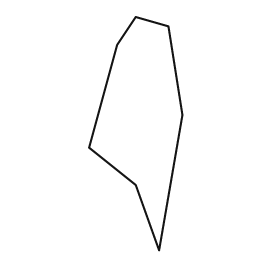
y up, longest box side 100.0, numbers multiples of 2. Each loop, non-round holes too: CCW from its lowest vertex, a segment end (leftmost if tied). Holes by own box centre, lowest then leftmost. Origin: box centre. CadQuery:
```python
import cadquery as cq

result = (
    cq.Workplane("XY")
    .moveTo(10.0, -50.0)
    .lineTo(20.0, 8.0)
    .lineTo(14.0, 46.0)
    .lineTo(0.0, 50.0)
    .lineTo(-8.0, 38.0)
    .lineTo(-20.0, -6.0)
    .lineTo(0.0, -22.0)
    .close()
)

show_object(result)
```